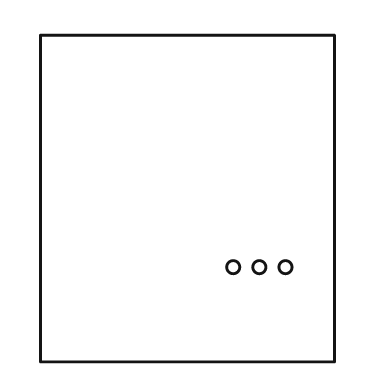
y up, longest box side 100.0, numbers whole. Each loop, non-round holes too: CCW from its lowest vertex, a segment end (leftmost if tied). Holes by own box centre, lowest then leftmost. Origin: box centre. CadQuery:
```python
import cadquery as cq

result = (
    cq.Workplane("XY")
    .moveTo(-45.0, -50.0)
    .lineTo(45.0, -50.0)
    .lineTo(45.0, 50.0)
    .lineTo(-45.0, 50.0)
    .close()
    .moveTo(14.0, -21.0)
    .circle(2.0)
    .moveTo(22.0, -21.0)
    .circle(2.0)
    .moveTo(30.0, -21.0)
    .circle(2.0)
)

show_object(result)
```